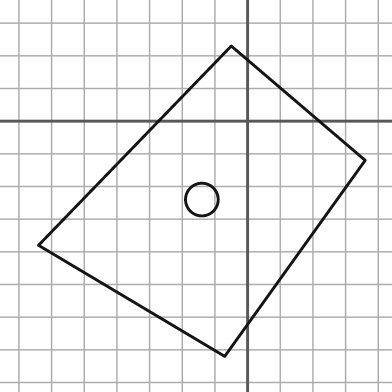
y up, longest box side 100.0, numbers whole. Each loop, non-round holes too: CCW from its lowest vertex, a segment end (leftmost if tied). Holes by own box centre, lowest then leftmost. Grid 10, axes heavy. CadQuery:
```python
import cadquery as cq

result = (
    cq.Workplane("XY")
    .moveTo(-7.0, -72.0)
    .lineTo(36.0, -12.0)
    .lineTo(-5.0, 23.0)
    .lineTo(-64.0, -38.0)
    .close()
    .moveTo(-14.0, -24.0)
    .circle(5.0)
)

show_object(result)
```